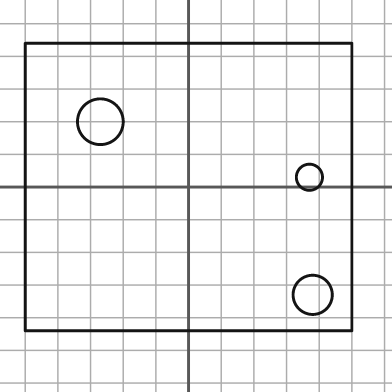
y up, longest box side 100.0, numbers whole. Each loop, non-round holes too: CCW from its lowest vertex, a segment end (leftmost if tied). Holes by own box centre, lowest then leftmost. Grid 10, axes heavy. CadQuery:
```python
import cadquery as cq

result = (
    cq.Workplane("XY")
    .moveTo(-50.0, -44.0)
    .lineTo(50.0, -44.0)
    .lineTo(50.0, 44.0)
    .lineTo(-50.0, 44.0)
    .close()
    .moveTo(38.0, -33.0)
    .circle(6.0)
    .moveTo(37.0, 3.0)
    .circle(4.0)
    .moveTo(-27.0, 20.0)
    .circle(7.0)
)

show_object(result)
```